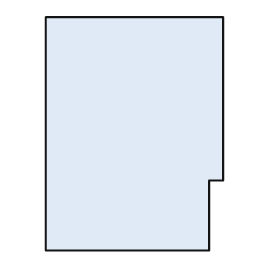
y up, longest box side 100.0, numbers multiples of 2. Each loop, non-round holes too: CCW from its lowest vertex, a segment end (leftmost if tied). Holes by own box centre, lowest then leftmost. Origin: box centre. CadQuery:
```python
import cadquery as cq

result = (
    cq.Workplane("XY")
    .moveTo(-38.0, -50.0)
    .lineTo(32.0, -50.0)
    .lineTo(32.0, -20.0)
    .lineTo(38.0, -20.0)
    .lineTo(38.0, 50.0)
    .lineTo(-38.0, 50.0)
    .close()
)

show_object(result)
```